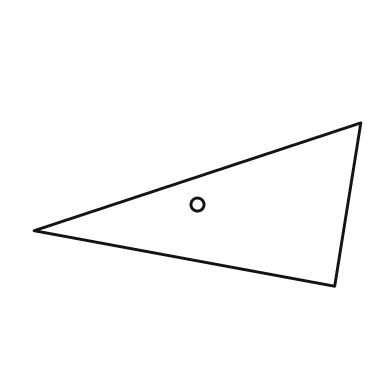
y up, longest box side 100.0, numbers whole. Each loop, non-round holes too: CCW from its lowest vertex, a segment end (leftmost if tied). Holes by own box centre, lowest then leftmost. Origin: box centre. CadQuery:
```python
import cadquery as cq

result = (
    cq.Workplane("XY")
    .moveTo(42.0, -25.0)
    .lineTo(50.0, 25.0)
    .lineTo(-50.0, -8.0)
    .close()
    .moveTo(0.0, 0.0)
    .circle(2.0)
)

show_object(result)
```